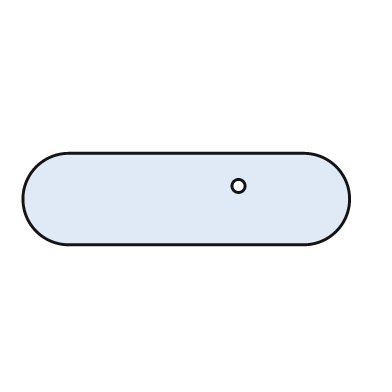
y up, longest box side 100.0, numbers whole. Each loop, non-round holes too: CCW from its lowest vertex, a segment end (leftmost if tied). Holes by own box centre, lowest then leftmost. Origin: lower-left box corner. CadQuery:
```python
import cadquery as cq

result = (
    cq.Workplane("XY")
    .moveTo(14.0, 0.0)
    .lineTo(86.0, 0.0)
    .threePointArc((100.0, 14.0), (86.0, 28.0))
    .lineTo(14.0, 28.0)
    .threePointArc((0.0, 14.0), (14.0, 0.0))
    .close()
    .moveTo(66.0, 18.0)
    .circle(2.0)
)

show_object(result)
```